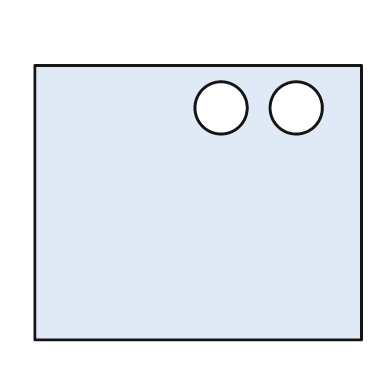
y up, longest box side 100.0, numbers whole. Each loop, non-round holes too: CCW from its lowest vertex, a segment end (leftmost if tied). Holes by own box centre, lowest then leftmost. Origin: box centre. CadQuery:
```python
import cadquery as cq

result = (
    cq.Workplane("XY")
    .moveTo(-50.0, -42.0)
    .lineTo(50.0, -42.0)
    .lineTo(50.0, 42.0)
    .lineTo(-50.0, 42.0)
    .close()
    .moveTo(7.0, 29.0)
    .circle(8.0)
    .moveTo(30.0, 29.0)
    .circle(8.0)
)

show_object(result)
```